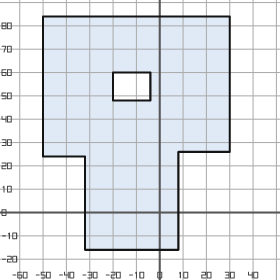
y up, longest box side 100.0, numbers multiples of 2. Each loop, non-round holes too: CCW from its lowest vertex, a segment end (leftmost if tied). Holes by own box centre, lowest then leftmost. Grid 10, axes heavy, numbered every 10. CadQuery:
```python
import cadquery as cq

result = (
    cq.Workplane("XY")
    .moveTo(-32.0, -16.0)
    .lineTo(8.0, -16.0)
    .lineTo(8.0, 26.0)
    .lineTo(30.0, 26.0)
    .lineTo(30.0, 84.0)
    .lineTo(-50.0, 84.0)
    .lineTo(-50.0, 24.0)
    .lineTo(-32.0, 24.0)
    .close()
    .moveTo(-20.0, 48.0)
    .lineTo(-4.0, 48.0)
    .lineTo(-4.0, 60.0)
    .lineTo(-20.0, 60.0)
    .close()
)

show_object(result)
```